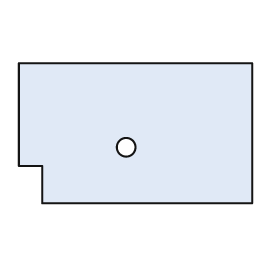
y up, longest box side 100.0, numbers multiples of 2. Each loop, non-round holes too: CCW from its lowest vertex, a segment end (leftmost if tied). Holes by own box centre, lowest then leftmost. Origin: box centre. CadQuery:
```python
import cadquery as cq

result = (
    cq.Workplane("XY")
    .moveTo(-40.0, -30.0)
    .lineTo(50.0, -30.0)
    .lineTo(50.0, 30.0)
    .lineTo(-50.0, 30.0)
    .lineTo(-50.0, -14.0)
    .lineTo(-40.0, -14.0)
    .close()
    .moveTo(-4.0, -6.0)
    .circle(4.0)
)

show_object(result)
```